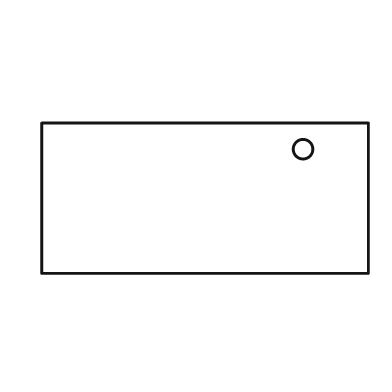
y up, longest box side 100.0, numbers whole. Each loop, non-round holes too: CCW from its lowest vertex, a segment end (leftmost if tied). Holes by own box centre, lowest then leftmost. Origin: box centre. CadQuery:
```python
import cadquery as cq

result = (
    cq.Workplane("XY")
    .moveTo(-50.0, -23.0)
    .lineTo(50.0, -23.0)
    .lineTo(50.0, 23.0)
    .lineTo(-50.0, 23.0)
    .close()
    .moveTo(30.0, 15.0)
    .circle(3.0)
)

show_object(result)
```